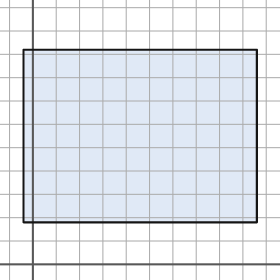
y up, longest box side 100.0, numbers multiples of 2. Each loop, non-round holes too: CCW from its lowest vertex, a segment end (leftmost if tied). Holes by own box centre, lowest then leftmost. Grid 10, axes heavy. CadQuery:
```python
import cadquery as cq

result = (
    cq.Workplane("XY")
    .moveTo(-4.0, 18.0)
    .lineTo(96.0, 18.0)
    .lineTo(96.0, 92.0)
    .lineTo(-4.0, 92.0)
    .close()
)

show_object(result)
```